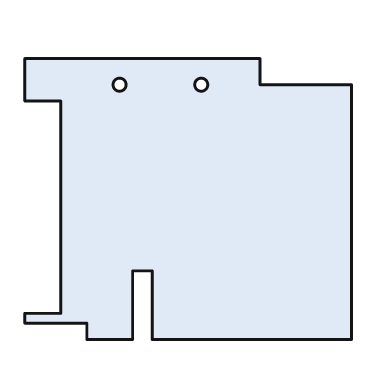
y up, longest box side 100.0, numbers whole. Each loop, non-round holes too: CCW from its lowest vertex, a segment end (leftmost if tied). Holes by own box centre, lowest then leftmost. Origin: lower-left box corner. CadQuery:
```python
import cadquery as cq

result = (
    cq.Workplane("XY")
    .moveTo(19.0, 0.0)
    .lineTo(33.0, 0.0)
    .lineTo(33.0, 21.0)
    .lineTo(39.0, 21.0)
    .lineTo(39.0, 0.0)
    .lineTo(100.0, 0.0)
    .lineTo(100.0, 78.0)
    .lineTo(72.0, 78.0)
    .lineTo(72.0, 86.0)
    .lineTo(0.0, 86.0)
    .lineTo(0.0, 73.0)
    .lineTo(11.0, 73.0)
    .lineTo(11.0, 8.0)
    .lineTo(0.0, 8.0)
    .lineTo(0.0, 5.0)
    .lineTo(19.0, 5.0)
    .close()
    .moveTo(29.0, 78.0)
    .circle(2.0)
    .moveTo(54.0, 78.0)
    .circle(2.0)
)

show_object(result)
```